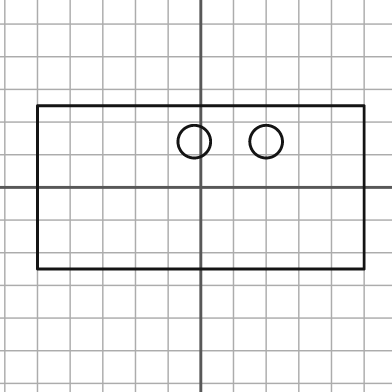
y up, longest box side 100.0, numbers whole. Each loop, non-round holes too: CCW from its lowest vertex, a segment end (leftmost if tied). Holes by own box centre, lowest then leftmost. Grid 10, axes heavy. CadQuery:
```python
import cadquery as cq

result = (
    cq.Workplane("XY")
    .moveTo(-50.0, -25.0)
    .lineTo(50.0, -25.0)
    .lineTo(50.0, 25.0)
    .lineTo(-50.0, 25.0)
    .close()
    .moveTo(-2.0, 14.0)
    .circle(5.0)
    .moveTo(20.0, 14.0)
    .circle(5.0)
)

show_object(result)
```